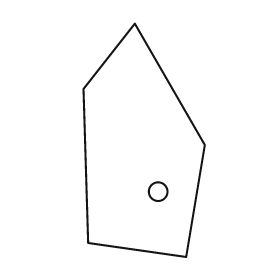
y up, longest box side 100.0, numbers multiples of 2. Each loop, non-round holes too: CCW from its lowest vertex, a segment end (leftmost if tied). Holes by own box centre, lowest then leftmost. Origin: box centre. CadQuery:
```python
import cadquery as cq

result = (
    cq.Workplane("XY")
    .moveTo(18.0, -50.0)
    .lineTo(26.0, -2.0)
    .lineTo(-4.0, 50.0)
    .lineTo(-26.0, 22.0)
    .lineTo(-24.0, -44.0)
    .close()
    .moveTo(6.0, -22.0)
    .circle(4.0)
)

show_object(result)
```